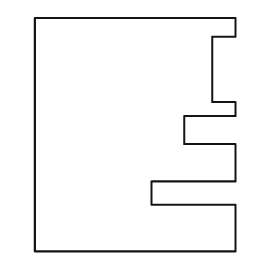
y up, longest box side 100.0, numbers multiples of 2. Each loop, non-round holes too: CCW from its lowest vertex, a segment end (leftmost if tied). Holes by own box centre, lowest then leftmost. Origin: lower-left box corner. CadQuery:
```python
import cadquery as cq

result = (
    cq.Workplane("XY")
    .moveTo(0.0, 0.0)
    .lineTo(86.0, 0.0)
    .lineTo(86.0, 20.0)
    .lineTo(50.0, 20.0)
    .lineTo(50.0, 30.0)
    .lineTo(86.0, 30.0)
    .lineTo(86.0, 46.0)
    .lineTo(64.0, 46.0)
    .lineTo(64.0, 58.0)
    .lineTo(86.0, 58.0)
    .lineTo(86.0, 64.0)
    .lineTo(76.0, 64.0)
    .lineTo(76.0, 92.0)
    .lineTo(86.0, 92.0)
    .lineTo(86.0, 100.0)
    .lineTo(0.0, 100.0)
    .close()
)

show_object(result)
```